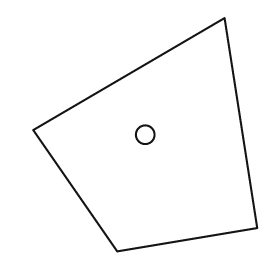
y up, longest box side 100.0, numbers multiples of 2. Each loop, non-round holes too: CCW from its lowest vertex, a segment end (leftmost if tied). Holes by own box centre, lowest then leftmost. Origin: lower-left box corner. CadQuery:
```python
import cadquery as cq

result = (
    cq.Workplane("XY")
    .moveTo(36.0, 0.0)
    .lineTo(96.0, 10.0)
    .lineTo(82.0, 100.0)
    .lineTo(0.0, 52.0)
    .close()
    .moveTo(48.0, 50.0)
    .circle(4.0)
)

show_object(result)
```